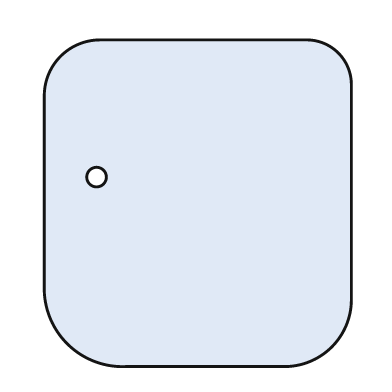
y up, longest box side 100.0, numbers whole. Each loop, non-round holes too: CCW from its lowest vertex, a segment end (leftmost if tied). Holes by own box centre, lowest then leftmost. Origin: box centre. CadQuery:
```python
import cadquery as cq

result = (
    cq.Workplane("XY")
    .moveTo(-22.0, -50.0)
    .lineTo(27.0, -50.0)
    .threePointArc((41.0, -44.0), (47.0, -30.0))
    .lineTo(47.0, 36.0)
    .threePointArc((43.0, 46.0), (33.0, 50.0))
    .lineTo(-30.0, 50.0)
    .threePointArc((-42.0, 45.0), (-47.0, 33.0))
    .lineTo(-47.0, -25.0)
    .threePointArc((-40.0, -43.0), (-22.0, -50.0))
    .close()
    .moveTo(-31.0, 8.0)
    .circle(3.0)
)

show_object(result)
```